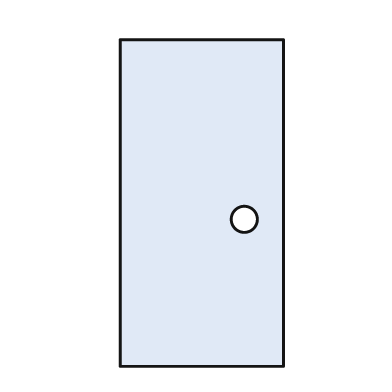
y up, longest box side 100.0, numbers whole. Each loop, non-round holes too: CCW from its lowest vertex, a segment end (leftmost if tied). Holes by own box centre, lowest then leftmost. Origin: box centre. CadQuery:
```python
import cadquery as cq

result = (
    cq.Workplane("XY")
    .moveTo(-25.0, -50.0)
    .lineTo(25.0, -50.0)
    .lineTo(25.0, 50.0)
    .lineTo(-25.0, 50.0)
    .close()
    .moveTo(13.0, -5.0)
    .circle(4.0)
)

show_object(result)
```